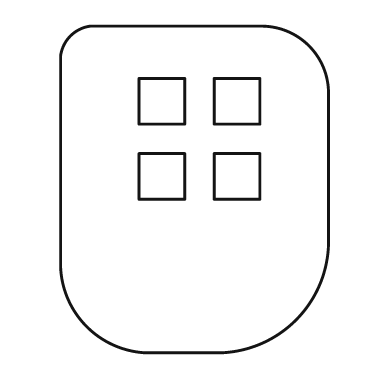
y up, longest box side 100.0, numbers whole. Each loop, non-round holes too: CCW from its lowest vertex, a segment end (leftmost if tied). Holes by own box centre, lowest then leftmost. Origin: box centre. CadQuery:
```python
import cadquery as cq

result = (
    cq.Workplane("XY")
    .moveTo(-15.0, -50.0)
    .lineTo(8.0, -50.0)
    .threePointArc((31.0, -40.0), (41.0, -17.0))
    .lineTo(41.0, 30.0)
    .threePointArc((35.0, 44.0), (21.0, 50.0))
    .lineTo(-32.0, 50.0)
    .threePointArc((-38.0, 47.0), (-41.0, 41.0))
    .lineTo(-41.0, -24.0)
    .threePointArc((-33.0, -42.0), (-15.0, -50.0))
    .close()
    .moveTo(-17.0, -3.0)
    .lineTo(-3.0, -3.0)
    .lineTo(-3.0, 11.0)
    .lineTo(-17.0, 11.0)
    .close()
    .moveTo(6.0, -3.0)
    .lineTo(20.0, -3.0)
    .lineTo(20.0, 11.0)
    .lineTo(6.0, 11.0)
    .close()
    .moveTo(-17.0, 20.0)
    .lineTo(-3.0, 20.0)
    .lineTo(-3.0, 34.0)
    .lineTo(-17.0, 34.0)
    .close()
    .moveTo(6.0, 20.0)
    .lineTo(20.0, 20.0)
    .lineTo(20.0, 34.0)
    .lineTo(6.0, 34.0)
    .close()
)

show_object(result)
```